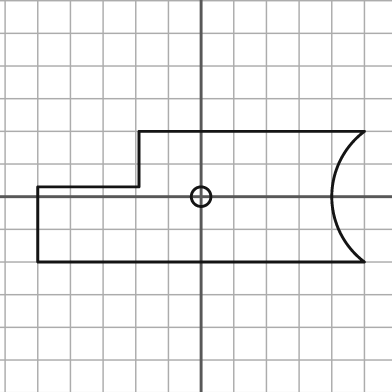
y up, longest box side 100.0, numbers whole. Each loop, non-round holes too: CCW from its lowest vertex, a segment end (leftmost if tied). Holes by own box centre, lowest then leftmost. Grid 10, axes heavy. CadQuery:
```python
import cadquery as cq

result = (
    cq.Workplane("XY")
    .moveTo(-50.0, -20.0)
    .lineTo(50.0, -20.0)
    .threePointArc((40.0, 0.0), (50.0, 20.0))
    .lineTo(-19.0, 20.0)
    .lineTo(-19.0, 3.0)
    .lineTo(-50.0, 3.0)
    .close()
    .moveTo(0.0, 0.0)
    .circle(3.0)
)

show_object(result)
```